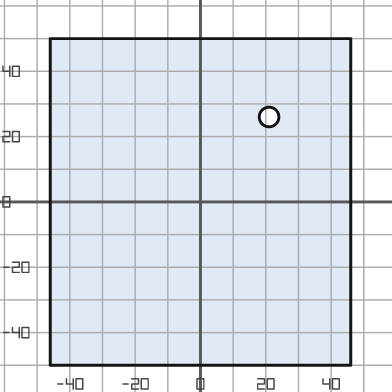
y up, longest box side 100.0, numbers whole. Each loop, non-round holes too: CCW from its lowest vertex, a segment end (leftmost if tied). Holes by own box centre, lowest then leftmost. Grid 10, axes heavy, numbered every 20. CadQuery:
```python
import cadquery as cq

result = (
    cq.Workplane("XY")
    .moveTo(-46.0, -50.0)
    .lineTo(46.0, -50.0)
    .lineTo(46.0, 50.0)
    .lineTo(-46.0, 50.0)
    .close()
    .moveTo(21.0, 26.0)
    .circle(3.0)
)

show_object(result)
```